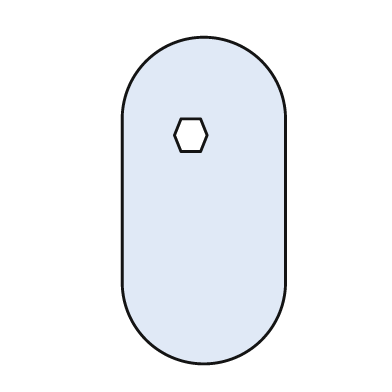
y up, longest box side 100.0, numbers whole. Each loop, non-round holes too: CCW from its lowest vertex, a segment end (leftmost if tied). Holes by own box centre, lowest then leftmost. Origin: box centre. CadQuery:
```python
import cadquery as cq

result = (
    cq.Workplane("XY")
    .moveTo(-25.0, -25.0)
    .threePointArc((0.0, -50.0), (25.0, -25.0))
    .lineTo(25.0, 25.0)
    .threePointArc((0.0, 50.0), (-25.0, 25.0))
    .close()
    .moveTo(-7.0, 15.0)
    .lineTo(-1.0, 15.0)
    .lineTo(1.0, 20.0)
    .lineTo(-1.0, 25.0)
    .lineTo(-7.0, 25.0)
    .lineTo(-9.0, 20.0)
    .close()
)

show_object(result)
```